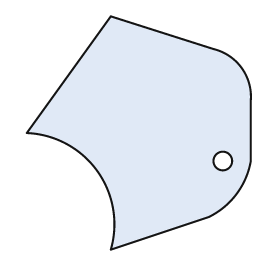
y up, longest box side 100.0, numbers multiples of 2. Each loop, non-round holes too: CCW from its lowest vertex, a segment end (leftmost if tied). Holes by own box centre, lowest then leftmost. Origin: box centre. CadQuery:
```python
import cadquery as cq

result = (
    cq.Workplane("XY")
    .moveTo(-12.0, -50.0)
    .lineTo(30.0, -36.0)
    .threePointArc((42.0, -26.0), (48.0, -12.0))
    .lineTo(48.0, 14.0)
    .threePointArc((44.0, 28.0), (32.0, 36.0))
    .lineTo(-12.0, 50.0)
    .lineTo(-48.0, 0.0)
    .threePointArc((-18.0, -16.0), (-12.0, -50.0))
    .close()
    .moveTo(36.0, -12.0)
    .circle(4.0)
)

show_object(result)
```